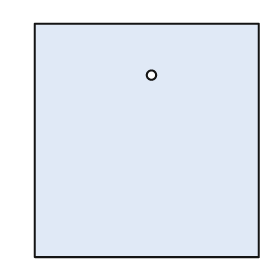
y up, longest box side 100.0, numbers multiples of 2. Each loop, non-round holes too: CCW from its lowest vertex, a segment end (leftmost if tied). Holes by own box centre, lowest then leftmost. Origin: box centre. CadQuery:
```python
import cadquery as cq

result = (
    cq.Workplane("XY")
    .moveTo(-48.0, -50.0)
    .lineTo(48.0, -50.0)
    .lineTo(48.0, 50.0)
    .lineTo(-48.0, 50.0)
    .close()
    .moveTo(2.0, 28.0)
    .circle(2.0)
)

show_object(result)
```